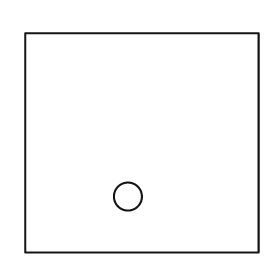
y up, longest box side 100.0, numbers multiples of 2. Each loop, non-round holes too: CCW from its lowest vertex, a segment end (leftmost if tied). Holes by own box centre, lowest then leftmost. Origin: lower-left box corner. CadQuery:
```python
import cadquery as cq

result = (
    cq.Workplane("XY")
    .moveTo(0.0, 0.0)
    .lineTo(100.0, 0.0)
    .lineTo(100.0, 94.0)
    .lineTo(0.0, 94.0)
    .close()
    .moveTo(44.0, 24.0)
    .circle(6.0)
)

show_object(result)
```